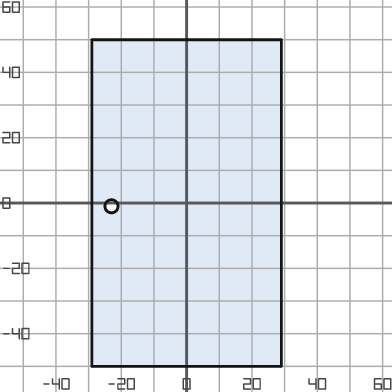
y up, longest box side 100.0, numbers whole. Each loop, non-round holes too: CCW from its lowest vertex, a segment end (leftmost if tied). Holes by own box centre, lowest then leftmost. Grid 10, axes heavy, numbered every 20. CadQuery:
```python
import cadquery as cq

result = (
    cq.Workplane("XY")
    .moveTo(-29.0, -50.0)
    .lineTo(29.0, -50.0)
    .lineTo(29.0, 50.0)
    .lineTo(-29.0, 50.0)
    .close()
    .moveTo(-23.0, -1.0)
    .circle(2.0)
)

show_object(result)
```